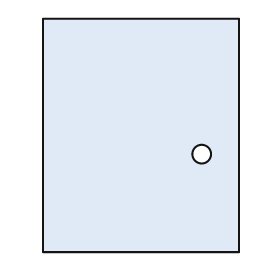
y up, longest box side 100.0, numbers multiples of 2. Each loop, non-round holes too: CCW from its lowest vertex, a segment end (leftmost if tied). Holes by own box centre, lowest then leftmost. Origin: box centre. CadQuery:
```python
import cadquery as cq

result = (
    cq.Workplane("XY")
    .moveTo(-42.0, -50.0)
    .lineTo(42.0, -50.0)
    .lineTo(42.0, 50.0)
    .lineTo(-42.0, 50.0)
    .close()
    .moveTo(26.0, -8.0)
    .circle(4.0)
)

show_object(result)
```